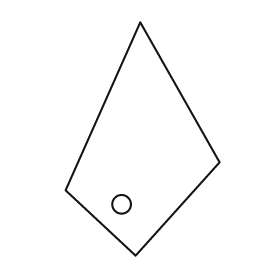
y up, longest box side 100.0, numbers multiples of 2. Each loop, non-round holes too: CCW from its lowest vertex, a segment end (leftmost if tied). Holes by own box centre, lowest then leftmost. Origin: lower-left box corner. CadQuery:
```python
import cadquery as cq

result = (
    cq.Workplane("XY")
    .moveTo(30.0, 0.0)
    .lineTo(66.0, 40.0)
    .lineTo(32.0, 100.0)
    .lineTo(0.0, 28.0)
    .close()
    .moveTo(24.0, 22.0)
    .circle(4.0)
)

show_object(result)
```